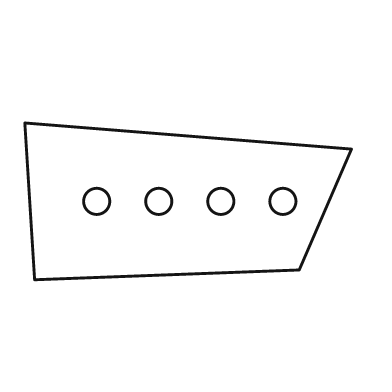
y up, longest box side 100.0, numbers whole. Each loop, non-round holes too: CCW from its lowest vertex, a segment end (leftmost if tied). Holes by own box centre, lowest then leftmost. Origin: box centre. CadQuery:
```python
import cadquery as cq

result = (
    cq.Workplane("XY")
    .moveTo(-47.0, -24.0)
    .lineTo(34.0, -21.0)
    .lineTo(50.0, 16.0)
    .lineTo(-50.0, 24.0)
    .close()
    .moveTo(-28.0, 0.0)
    .circle(4.0)
    .moveTo(-9.0, 0.0)
    .circle(4.0)
    .moveTo(10.0, 0.0)
    .circle(4.0)
    .moveTo(29.0, 0.0)
    .circle(4.0)
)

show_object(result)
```